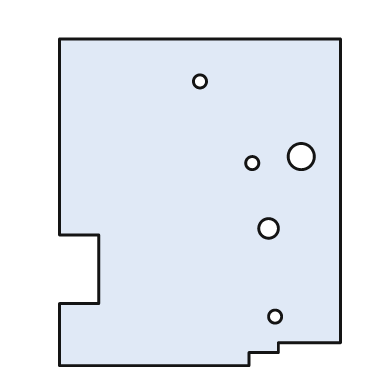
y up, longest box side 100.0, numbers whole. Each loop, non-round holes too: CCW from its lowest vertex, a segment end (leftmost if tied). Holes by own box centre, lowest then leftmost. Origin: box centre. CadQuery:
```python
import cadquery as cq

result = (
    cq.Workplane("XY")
    .moveTo(-43.0, -50.0)
    .lineTo(15.0, -50.0)
    .lineTo(15.0, -46.0)
    .lineTo(24.0, -46.0)
    .lineTo(24.0, -43.0)
    .lineTo(43.0, -43.0)
    .lineTo(43.0, 50.0)
    .lineTo(-43.0, 50.0)
    .lineTo(-43.0, -10.0)
    .lineTo(-31.0, -10.0)
    .lineTo(-31.0, -31.0)
    .lineTo(-43.0, -31.0)
    .close()
    .moveTo(23.0, -35.0)
    .circle(2.0)
    .moveTo(21.0, -8.0)
    .circle(3.0)
    .moveTo(16.0, 12.0)
    .circle(2.0)
    .moveTo(31.0, 14.0)
    .circle(4.0)
    .moveTo(0.0, 37.0)
    .circle(2.0)
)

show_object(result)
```